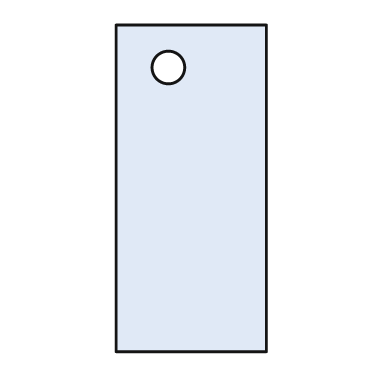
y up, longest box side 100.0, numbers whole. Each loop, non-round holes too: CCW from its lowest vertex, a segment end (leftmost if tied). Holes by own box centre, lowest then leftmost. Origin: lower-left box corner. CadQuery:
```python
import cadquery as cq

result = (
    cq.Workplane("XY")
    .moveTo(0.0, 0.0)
    .lineTo(46.0, 0.0)
    .lineTo(46.0, 100.0)
    .lineTo(0.0, 100.0)
    .close()
    .moveTo(16.0, 87.0)
    .circle(5.0)
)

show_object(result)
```